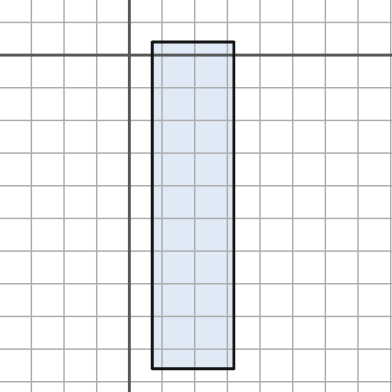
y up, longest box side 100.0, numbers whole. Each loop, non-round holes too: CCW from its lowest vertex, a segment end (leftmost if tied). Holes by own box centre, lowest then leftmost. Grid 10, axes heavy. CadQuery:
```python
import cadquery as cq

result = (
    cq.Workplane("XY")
    .moveTo(7.0, -96.0)
    .lineTo(32.0, -96.0)
    .lineTo(32.0, 4.0)
    .lineTo(7.0, 4.0)
    .close()
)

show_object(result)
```